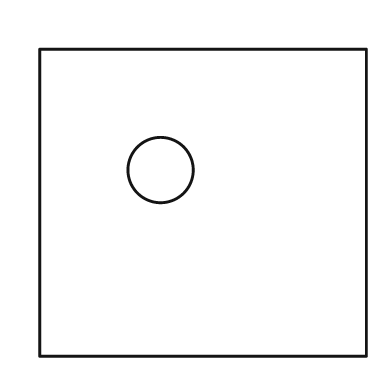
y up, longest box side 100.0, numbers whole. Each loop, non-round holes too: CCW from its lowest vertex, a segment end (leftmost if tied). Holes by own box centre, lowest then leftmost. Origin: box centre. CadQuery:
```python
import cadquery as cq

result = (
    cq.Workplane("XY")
    .moveTo(-50.0, -47.0)
    .lineTo(50.0, -47.0)
    .lineTo(50.0, 47.0)
    .lineTo(-50.0, 47.0)
    .close()
    .moveTo(-13.0, 10.0)
    .circle(10.0)
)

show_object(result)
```